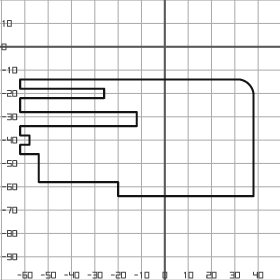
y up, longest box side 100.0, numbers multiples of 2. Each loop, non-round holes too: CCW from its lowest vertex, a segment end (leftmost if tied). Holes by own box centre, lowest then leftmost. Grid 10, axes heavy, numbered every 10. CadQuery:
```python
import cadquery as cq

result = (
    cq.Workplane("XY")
    .moveTo(-20.0, -64.0)
    .lineTo(38.0, -64.0)
    .lineTo(38.0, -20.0)
    .threePointArc((36.0, -16.0), (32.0, -14.0))
    .lineTo(-62.0, -14.0)
    .lineTo(-62.0, -18.0)
    .lineTo(-26.0, -18.0)
    .lineTo(-26.0, -22.0)
    .lineTo(-62.0, -22.0)
    .lineTo(-62.0, -28.0)
    .lineTo(-12.0, -28.0)
    .lineTo(-12.0, -34.0)
    .lineTo(-62.0, -34.0)
    .lineTo(-62.0, -38.0)
    .lineTo(-58.0, -38.0)
    .lineTo(-58.0, -42.0)
    .lineTo(-62.0, -42.0)
    .lineTo(-62.0, -46.0)
    .lineTo(-54.0, -46.0)
    .lineTo(-54.0, -58.0)
    .lineTo(-20.0, -58.0)
    .close()
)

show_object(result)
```